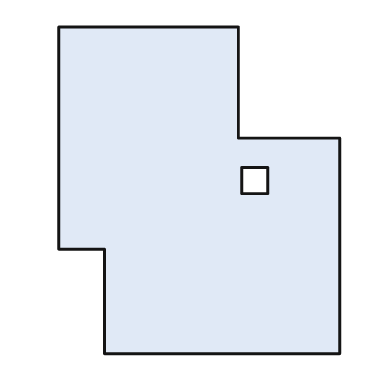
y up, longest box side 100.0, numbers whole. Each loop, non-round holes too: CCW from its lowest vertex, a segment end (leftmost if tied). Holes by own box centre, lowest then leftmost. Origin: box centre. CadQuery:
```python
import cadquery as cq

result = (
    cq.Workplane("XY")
    .moveTo(-29.0, -50.0)
    .lineTo(43.0, -50.0)
    .lineTo(43.0, 16.0)
    .lineTo(12.0, 16.0)
    .lineTo(12.0, 50.0)
    .lineTo(-43.0, 50.0)
    .lineTo(-43.0, -18.0)
    .lineTo(-29.0, -18.0)
    .close()
    .moveTo(13.0, -1.0)
    .lineTo(21.0, -1.0)
    .lineTo(21.0, 7.0)
    .lineTo(13.0, 7.0)
    .close()
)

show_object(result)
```